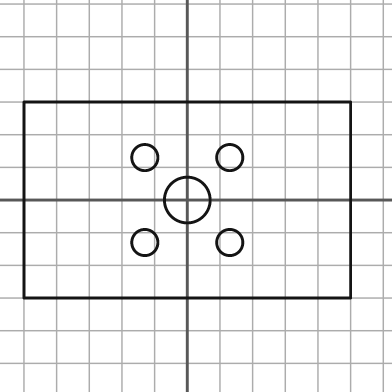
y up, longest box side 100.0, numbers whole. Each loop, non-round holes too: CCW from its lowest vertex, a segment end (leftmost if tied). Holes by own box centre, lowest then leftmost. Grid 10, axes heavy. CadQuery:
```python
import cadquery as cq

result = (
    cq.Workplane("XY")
    .moveTo(-50.0, -30.0)
    .lineTo(50.0, -30.0)
    .lineTo(50.0, 30.0)
    .lineTo(-50.0, 30.0)
    .close()
    .moveTo(-13.0, -13.0)
    .circle(4.0)
    .moveTo(13.0, -13.0)
    .circle(4.0)
    .moveTo(0.0, 0.0)
    .circle(7.0)
    .moveTo(-13.0, 13.0)
    .circle(4.0)
    .moveTo(13.0, 13.0)
    .circle(4.0)
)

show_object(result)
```